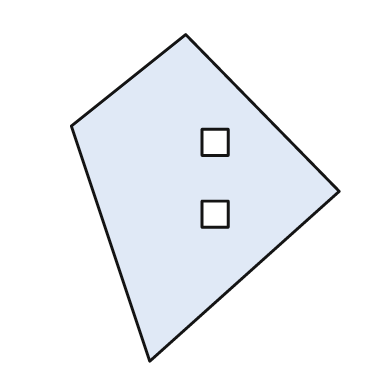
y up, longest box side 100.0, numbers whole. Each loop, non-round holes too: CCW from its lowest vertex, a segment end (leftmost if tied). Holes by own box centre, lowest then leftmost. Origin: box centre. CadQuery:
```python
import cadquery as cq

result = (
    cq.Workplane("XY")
    .moveTo(-17.0, -50.0)
    .lineTo(41.0, 2.0)
    .lineTo(-6.0, 50.0)
    .lineTo(-41.0, 22.0)
    .close()
    .moveTo(-1.0, -9.0)
    .lineTo(7.0, -9.0)
    .lineTo(7.0, -1.0)
    .lineTo(-1.0, -1.0)
    .close()
    .moveTo(-1.0, 13.0)
    .lineTo(7.0, 13.0)
    .lineTo(7.0, 21.0)
    .lineTo(-1.0, 21.0)
    .close()
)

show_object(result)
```